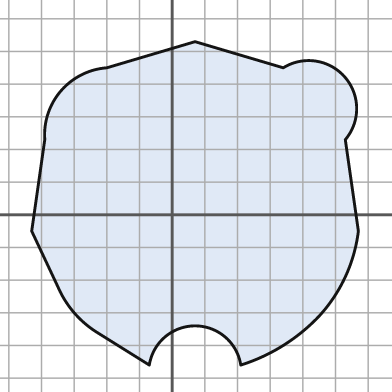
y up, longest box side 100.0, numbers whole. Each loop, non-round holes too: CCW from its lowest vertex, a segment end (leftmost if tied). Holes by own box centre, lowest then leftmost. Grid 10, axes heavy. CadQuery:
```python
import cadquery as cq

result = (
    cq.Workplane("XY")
    .moveTo(-7.0, -46.0)
    .threePointArc((7.0, -34.0), (21.0, -46.0))
    .threePointArc((34.0, -40.0), (45.0, -31.0))
    .threePointArc((53.0, -19.0), (57.0, -5.0))
    .lineTo(53.0, 23.0)
    .threePointArc((53.0, 42.0), (34.0, 45.0))
    .lineTo(7.0, 53.0)
    .lineTo(-20.0, 45.0)
    .threePointArc((-34.0, 38.0), (-39.0, 23.0))
    .lineTo(-43.0, -5.0)
    .lineTo(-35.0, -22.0)
    .threePointArc((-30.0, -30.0), (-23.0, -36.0))
    .close()
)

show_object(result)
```